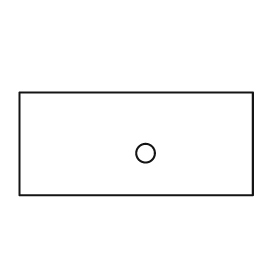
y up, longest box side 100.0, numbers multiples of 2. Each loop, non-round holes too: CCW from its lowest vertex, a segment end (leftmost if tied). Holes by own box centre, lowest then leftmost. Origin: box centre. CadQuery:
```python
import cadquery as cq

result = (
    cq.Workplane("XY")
    .moveTo(-50.0, -22.0)
    .lineTo(50.0, -22.0)
    .lineTo(50.0, 22.0)
    .lineTo(-50.0, 22.0)
    .close()
    .moveTo(4.0, -4.0)
    .circle(4.0)
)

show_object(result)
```